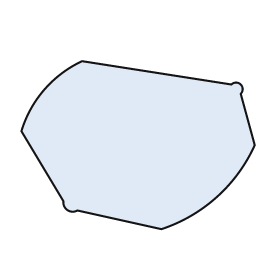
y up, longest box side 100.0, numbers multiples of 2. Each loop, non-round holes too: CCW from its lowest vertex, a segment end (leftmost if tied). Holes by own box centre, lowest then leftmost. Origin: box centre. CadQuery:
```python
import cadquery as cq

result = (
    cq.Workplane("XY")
    .moveTo(10.0, -36.0)
    .threePointArc((34.0, -22.0), (50.0, 0.0))
    .lineTo(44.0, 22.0)
    .threePointArc((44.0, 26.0), (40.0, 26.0))
    .lineTo(-24.0, 36.0)
    .threePointArc((-40.0, 24.0), (-50.0, 6.0))
    .lineTo(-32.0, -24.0)
    .threePointArc((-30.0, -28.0), (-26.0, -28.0))
    .close()
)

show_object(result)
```